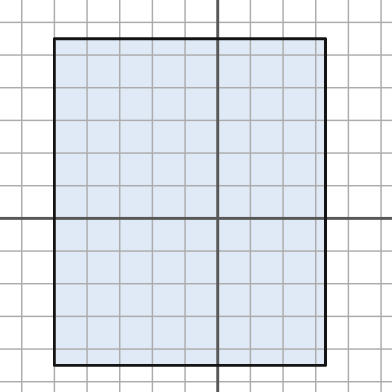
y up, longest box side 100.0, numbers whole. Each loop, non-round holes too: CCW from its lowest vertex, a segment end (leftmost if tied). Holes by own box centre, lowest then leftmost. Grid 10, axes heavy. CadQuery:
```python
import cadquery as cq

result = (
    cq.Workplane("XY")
    .moveTo(-50.0, -45.0)
    .lineTo(33.0, -45.0)
    .lineTo(33.0, 55.0)
    .lineTo(-50.0, 55.0)
    .close()
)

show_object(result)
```